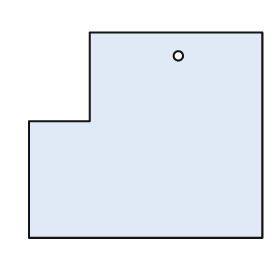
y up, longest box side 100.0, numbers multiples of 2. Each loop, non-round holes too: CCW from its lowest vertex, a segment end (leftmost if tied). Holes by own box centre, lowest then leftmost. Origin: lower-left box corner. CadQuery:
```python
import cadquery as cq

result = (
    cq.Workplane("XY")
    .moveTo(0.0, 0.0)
    .lineTo(100.0, 0.0)
    .lineTo(100.0, 88.0)
    .lineTo(26.0, 88.0)
    .lineTo(26.0, 50.0)
    .lineTo(0.0, 50.0)
    .close()
    .moveTo(64.0, 78.0)
    .circle(2.0)
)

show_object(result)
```